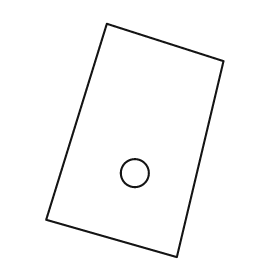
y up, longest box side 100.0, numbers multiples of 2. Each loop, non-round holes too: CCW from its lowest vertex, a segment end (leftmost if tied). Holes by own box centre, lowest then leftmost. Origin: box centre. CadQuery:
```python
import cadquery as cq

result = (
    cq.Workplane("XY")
    .moveTo(18.0, -50.0)
    .lineTo(38.0, 34.0)
    .lineTo(-12.0, 50.0)
    .lineTo(-38.0, -34.0)
    .close()
    .moveTo(0.0, -14.0)
    .circle(6.0)
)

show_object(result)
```